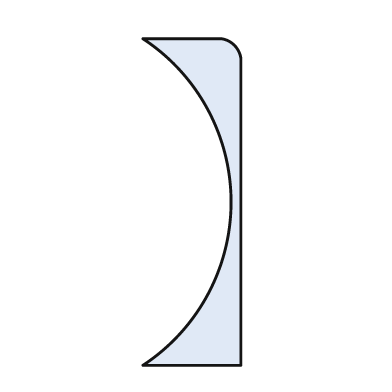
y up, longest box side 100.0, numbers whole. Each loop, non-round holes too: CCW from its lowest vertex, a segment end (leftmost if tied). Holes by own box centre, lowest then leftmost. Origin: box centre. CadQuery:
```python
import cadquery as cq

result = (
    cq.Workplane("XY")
    .moveTo(-15.0, -50.0)
    .lineTo(15.0, -50.0)
    .lineTo(15.0, 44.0)
    .threePointArc((13.0, 48.0), (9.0, 50.0))
    .lineTo(-15.0, 50.0)
    .threePointArc((12.0, 0.0), (-15.0, -50.0))
    .close()
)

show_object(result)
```